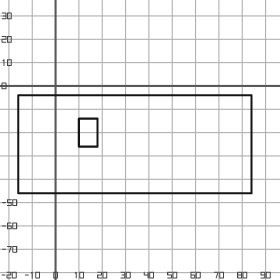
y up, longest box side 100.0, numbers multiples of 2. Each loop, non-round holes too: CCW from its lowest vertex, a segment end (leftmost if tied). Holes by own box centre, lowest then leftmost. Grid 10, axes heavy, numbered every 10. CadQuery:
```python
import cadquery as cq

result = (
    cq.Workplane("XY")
    .moveTo(-16.0, -46.0)
    .lineTo(84.0, -46.0)
    .lineTo(84.0, -4.0)
    .lineTo(-16.0, -4.0)
    .close()
    .moveTo(10.0, -26.0)
    .lineTo(18.0, -26.0)
    .lineTo(18.0, -14.0)
    .lineTo(10.0, -14.0)
    .close()
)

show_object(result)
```